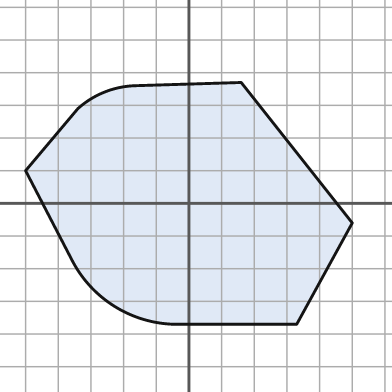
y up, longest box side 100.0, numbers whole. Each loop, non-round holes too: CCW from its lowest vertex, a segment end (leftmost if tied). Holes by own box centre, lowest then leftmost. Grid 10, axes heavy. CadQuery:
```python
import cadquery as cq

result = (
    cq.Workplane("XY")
    .moveTo(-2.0, -37.0)
    .lineTo(33.0, -37.0)
    .lineTo(50.0, -6.0)
    .lineTo(16.0, 37.0)
    .lineTo(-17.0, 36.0)
    .threePointArc((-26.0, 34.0), (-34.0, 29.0))
    .lineTo(-50.0, 10.0)
    .lineTo(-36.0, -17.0)
    .threePointArc((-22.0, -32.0), (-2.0, -37.0))
    .close()
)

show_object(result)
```